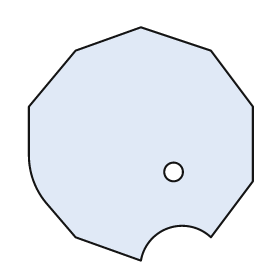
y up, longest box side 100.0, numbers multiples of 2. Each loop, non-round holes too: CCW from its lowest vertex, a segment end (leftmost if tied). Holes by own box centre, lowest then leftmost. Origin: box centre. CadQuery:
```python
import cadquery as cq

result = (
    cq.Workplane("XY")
    .moveTo(0.0, -50.0)
    .threePointArc((12.0, -36.0), (30.0, -40.0))
    .lineTo(48.0, -16.0)
    .lineTo(48.0, 16.0)
    .lineTo(30.0, 40.0)
    .lineTo(0.0, 50.0)
    .lineTo(-28.0, 40.0)
    .lineTo(-48.0, 16.0)
    .lineTo(-48.0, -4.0)
    .threePointArc((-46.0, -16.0), (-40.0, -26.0))
    .lineTo(-28.0, -40.0)
    .close()
    .moveTo(14.0, -12.0)
    .circle(4.0)
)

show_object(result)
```